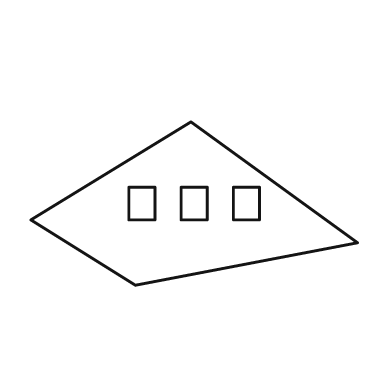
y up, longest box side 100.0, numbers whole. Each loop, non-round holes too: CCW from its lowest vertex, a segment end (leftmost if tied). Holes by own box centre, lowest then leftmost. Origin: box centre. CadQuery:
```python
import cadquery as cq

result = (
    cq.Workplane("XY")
    .moveTo(-18.0, -25.0)
    .lineTo(50.0, -12.0)
    .lineTo(-1.0, 25.0)
    .lineTo(-50.0, -5.0)
    .close()
    .moveTo(-20.0, -5.0)
    .lineTo(-12.0, -5.0)
    .lineTo(-12.0, 5.0)
    .lineTo(-20.0, 5.0)
    .close()
    .moveTo(-4.0, -5.0)
    .lineTo(4.0, -5.0)
    .lineTo(4.0, 5.0)
    .lineTo(-4.0, 5.0)
    .close()
    .moveTo(12.0, -5.0)
    .lineTo(20.0, -5.0)
    .lineTo(20.0, 5.0)
    .lineTo(12.0, 5.0)
    .close()
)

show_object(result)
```